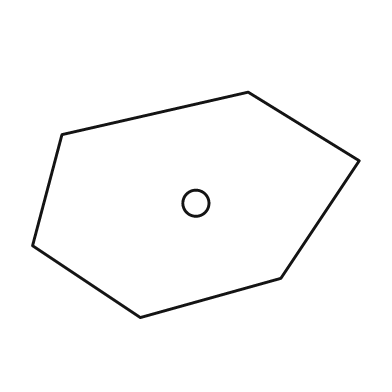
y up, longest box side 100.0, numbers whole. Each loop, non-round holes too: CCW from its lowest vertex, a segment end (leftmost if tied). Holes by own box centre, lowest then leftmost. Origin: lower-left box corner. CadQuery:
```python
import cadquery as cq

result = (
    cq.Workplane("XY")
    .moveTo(33.0, 0.0)
    .lineTo(76.0, 12.0)
    .lineTo(100.0, 48.0)
    .lineTo(66.0, 69.0)
    .lineTo(9.0, 56.0)
    .lineTo(0.0, 22.0)
    .close()
    .moveTo(50.0, 35.0)
    .circle(4.0)
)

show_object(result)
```